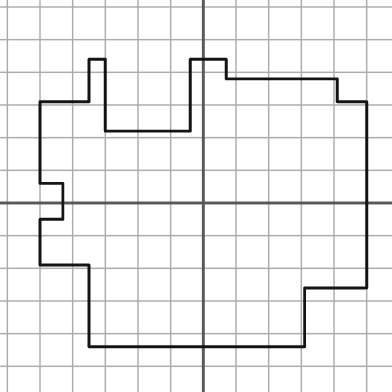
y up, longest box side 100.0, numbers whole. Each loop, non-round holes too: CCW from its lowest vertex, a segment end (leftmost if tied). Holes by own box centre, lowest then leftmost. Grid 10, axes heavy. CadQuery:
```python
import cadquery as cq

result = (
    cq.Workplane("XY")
    .moveTo(-35.0, -44.0)
    .lineTo(31.0, -44.0)
    .lineTo(31.0, -26.0)
    .lineTo(50.0, -26.0)
    .lineTo(50.0, 31.0)
    .lineTo(41.0, 31.0)
    .lineTo(41.0, 38.0)
    .lineTo(7.0, 38.0)
    .lineTo(7.0, 44.0)
    .lineTo(-4.0, 44.0)
    .lineTo(-4.0, 22.0)
    .lineTo(-30.0, 22.0)
    .lineTo(-30.0, 44.0)
    .lineTo(-35.0, 44.0)
    .lineTo(-35.0, 31.0)
    .lineTo(-50.0, 31.0)
    .lineTo(-50.0, 6.0)
    .lineTo(-43.0, 6.0)
    .lineTo(-43.0, -5.0)
    .lineTo(-50.0, -5.0)
    .lineTo(-50.0, -19.0)
    .lineTo(-35.0, -19.0)
    .close()
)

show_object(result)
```